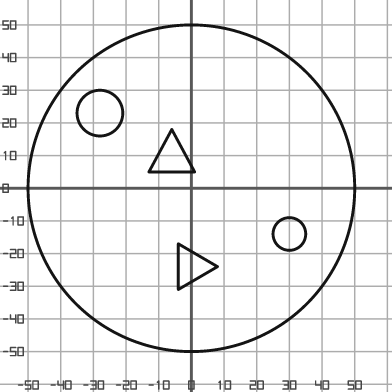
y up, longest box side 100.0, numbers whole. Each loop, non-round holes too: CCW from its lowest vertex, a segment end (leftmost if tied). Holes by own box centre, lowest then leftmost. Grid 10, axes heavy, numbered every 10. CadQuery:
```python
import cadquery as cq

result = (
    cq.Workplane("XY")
    .moveTo(0.0, 0.0)
    .circle(50.0)
    .moveTo(-4.0, -31.0)
    .lineTo(8.0, -24.0)
    .lineTo(-4.0, -17.0)
    .close()
    .moveTo(30.0, -14.0)
    .circle(5.0)
    .moveTo(-13.0, 5.0)
    .lineTo(1.0, 5.0)
    .lineTo(-6.0, 18.0)
    .close()
    .moveTo(-28.0, 23.0)
    .circle(7.0)
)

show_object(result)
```